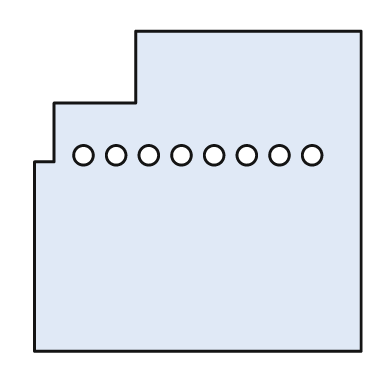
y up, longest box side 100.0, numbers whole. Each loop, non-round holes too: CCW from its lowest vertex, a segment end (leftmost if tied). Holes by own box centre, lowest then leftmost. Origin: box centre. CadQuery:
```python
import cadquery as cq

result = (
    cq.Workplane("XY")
    .moveTo(-50.0, -49.0)
    .lineTo(50.0, -49.0)
    .lineTo(50.0, 49.0)
    .lineTo(-19.0, 49.0)
    .lineTo(-19.0, 27.0)
    .lineTo(-44.0, 27.0)
    .lineTo(-44.0, 9.0)
    .lineTo(-50.0, 9.0)
    .close()
    .moveTo(-35.0, 11.0)
    .circle(3.0)
    .moveTo(-25.0, 11.0)
    .circle(3.0)
    .moveTo(-15.0, 11.0)
    .circle(3.0)
    .moveTo(-5.0, 11.0)
    .circle(3.0)
    .moveTo(5.0, 11.0)
    .circle(3.0)
    .moveTo(15.0, 11.0)
    .circle(3.0)
    .moveTo(25.0, 11.0)
    .circle(3.0)
    .moveTo(35.0, 11.0)
    .circle(3.0)
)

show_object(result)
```